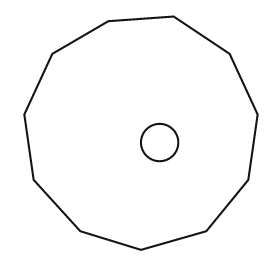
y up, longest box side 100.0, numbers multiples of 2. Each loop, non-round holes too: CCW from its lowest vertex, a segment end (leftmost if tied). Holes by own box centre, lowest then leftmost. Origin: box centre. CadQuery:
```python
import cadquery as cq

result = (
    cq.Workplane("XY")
    .moveTo(0.0, -50.0)
    .lineTo(28.0, -42.0)
    .lineTo(46.0, -20.0)
    .lineTo(50.0, 8.0)
    .lineTo(38.0, 34.0)
    .lineTo(14.0, 50.0)
    .lineTo(-14.0, 48.0)
    .lineTo(-38.0, 34.0)
    .lineTo(-50.0, 8.0)
    .lineTo(-46.0, -20.0)
    .lineTo(-26.0, -42.0)
    .close()
    .moveTo(8.0, -4.0)
    .circle(8.0)
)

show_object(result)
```